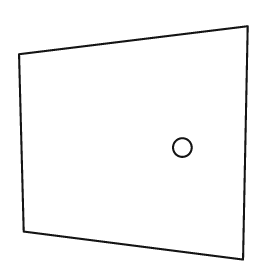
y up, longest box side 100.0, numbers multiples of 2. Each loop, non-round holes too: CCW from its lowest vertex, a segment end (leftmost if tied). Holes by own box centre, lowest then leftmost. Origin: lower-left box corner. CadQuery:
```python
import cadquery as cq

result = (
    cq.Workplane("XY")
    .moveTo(96.0, 0.0)
    .lineTo(98.0, 100.0)
    .lineTo(0.0, 88.0)
    .lineTo(2.0, 12.0)
    .close()
    .moveTo(70.0, 48.0)
    .circle(4.0)
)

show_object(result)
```